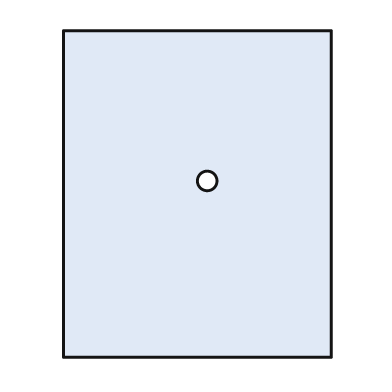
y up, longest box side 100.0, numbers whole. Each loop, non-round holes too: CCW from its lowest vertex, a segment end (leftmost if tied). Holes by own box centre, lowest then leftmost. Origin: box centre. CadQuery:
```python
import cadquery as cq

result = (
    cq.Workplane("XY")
    .moveTo(-41.0, -50.0)
    .lineTo(41.0, -50.0)
    .lineTo(41.0, 50.0)
    .lineTo(-41.0, 50.0)
    .close()
    .moveTo(3.0, 4.0)
    .circle(3.0)
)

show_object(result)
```